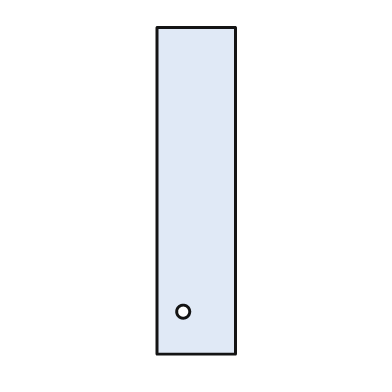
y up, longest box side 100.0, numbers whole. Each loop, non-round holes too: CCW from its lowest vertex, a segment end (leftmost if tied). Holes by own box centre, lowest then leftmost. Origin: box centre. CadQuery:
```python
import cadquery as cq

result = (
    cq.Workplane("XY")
    .moveTo(-12.0, -50.0)
    .lineTo(12.0, -50.0)
    .lineTo(12.0, 50.0)
    .lineTo(-12.0, 50.0)
    .close()
    .moveTo(-4.0, -37.0)
    .circle(2.0)
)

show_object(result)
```